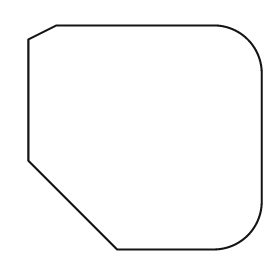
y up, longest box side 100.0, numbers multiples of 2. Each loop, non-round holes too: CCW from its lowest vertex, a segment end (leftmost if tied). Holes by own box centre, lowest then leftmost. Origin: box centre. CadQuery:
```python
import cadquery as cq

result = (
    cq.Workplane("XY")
    .moveTo(-12.0, -48.0)
    .lineTo(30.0, -48.0)
    .threePointArc((44.0, -42.0), (50.0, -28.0))
    .lineTo(50.0, 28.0)
    .threePointArc((44.0, 42.0), (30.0, 48.0))
    .lineTo(-38.0, 48.0)
    .lineTo(-50.0, 42.0)
    .lineTo(-50.0, -10.0)
    .close()
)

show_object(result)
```